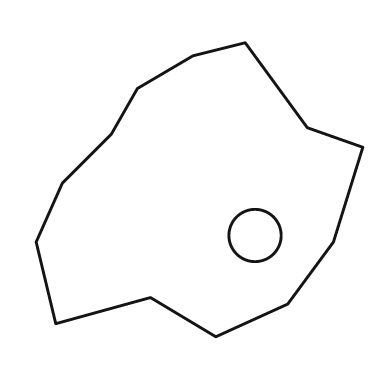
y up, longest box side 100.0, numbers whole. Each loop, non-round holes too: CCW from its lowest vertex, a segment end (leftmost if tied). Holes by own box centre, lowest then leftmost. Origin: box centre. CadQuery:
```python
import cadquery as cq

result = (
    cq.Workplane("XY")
    .moveTo(5.0, -45.0)
    .lineTo(27.0, -35.0)
    .lineTo(41.0, -16.0)
    .lineTo(50.0, 13.0)
    .lineTo(33.0, 19.0)
    .lineTo(14.0, 45.0)
    .lineTo(-2.0, 41.0)
    .lineTo(-19.0, 31.0)
    .lineTo(-27.0, 17.0)
    .lineTo(-42.0, 2.0)
    .lineTo(-50.0, -16.0)
    .lineTo(-44.0, -41.0)
    .lineTo(-15.0, -33.0)
    .close()
    .moveTo(17.0, -14.0)
    .circle(8.0)
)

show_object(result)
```